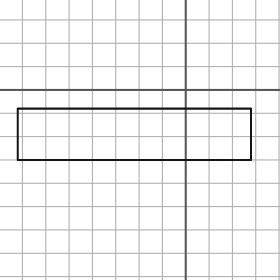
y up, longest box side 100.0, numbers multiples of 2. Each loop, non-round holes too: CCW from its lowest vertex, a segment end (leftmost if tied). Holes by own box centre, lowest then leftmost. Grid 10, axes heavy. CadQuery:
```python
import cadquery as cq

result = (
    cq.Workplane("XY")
    .moveTo(-72.0, -30.0)
    .lineTo(28.0, -30.0)
    .lineTo(28.0, -8.0)
    .lineTo(-72.0, -8.0)
    .close()
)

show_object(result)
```